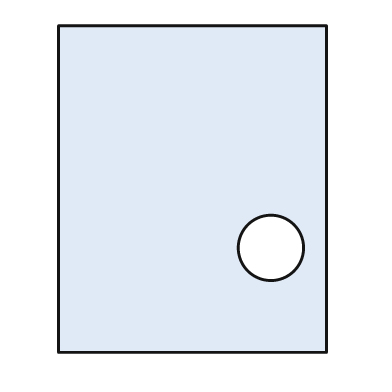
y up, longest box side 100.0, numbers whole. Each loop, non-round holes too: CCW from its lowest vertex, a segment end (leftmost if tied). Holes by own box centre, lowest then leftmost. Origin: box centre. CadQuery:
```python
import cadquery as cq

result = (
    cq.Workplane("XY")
    .moveTo(-41.0, -50.0)
    .lineTo(41.0, -50.0)
    .lineTo(41.0, 50.0)
    .lineTo(-41.0, 50.0)
    .close()
    .moveTo(24.0, -18.0)
    .circle(10.0)
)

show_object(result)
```